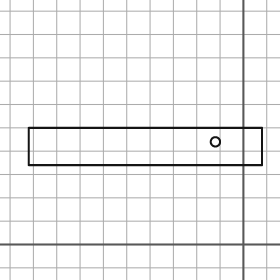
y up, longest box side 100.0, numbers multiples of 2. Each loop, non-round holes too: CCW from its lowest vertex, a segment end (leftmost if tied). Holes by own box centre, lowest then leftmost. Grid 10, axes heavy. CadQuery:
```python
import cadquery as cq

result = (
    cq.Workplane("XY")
    .moveTo(-92.0, 34.0)
    .lineTo(8.0, 34.0)
    .lineTo(8.0, 50.0)
    .lineTo(-92.0, 50.0)
    .close()
    .moveTo(-12.0, 44.0)
    .circle(2.0)
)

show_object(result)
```